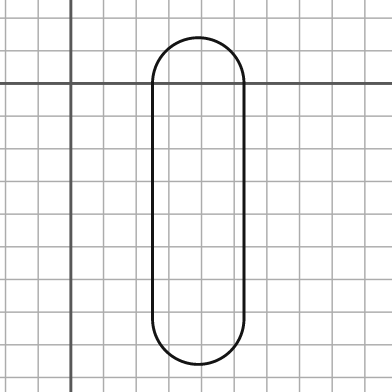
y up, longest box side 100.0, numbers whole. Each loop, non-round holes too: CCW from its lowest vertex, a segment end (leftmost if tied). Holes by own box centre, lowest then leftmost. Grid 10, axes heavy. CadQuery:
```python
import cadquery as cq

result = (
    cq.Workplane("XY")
    .moveTo(25.0, -72.0)
    .threePointArc((39.0, -86.0), (53.0, -72.0))
    .lineTo(53.0, 0.0)
    .threePointArc((39.0, 14.0), (25.0, 0.0))
    .close()
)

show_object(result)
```